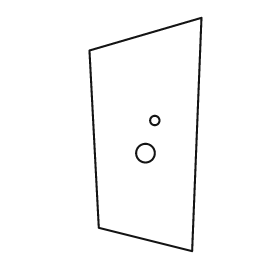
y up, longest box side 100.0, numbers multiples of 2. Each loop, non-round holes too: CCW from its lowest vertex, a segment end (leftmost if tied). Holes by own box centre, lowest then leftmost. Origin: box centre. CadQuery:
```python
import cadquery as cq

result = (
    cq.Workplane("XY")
    .moveTo(20.0, -50.0)
    .lineTo(24.0, 50.0)
    .lineTo(-24.0, 36.0)
    .lineTo(-20.0, -40.0)
    .close()
    .moveTo(0.0, -8.0)
    .circle(4.0)
    .moveTo(4.0, 6.0)
    .circle(2.0)
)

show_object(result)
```